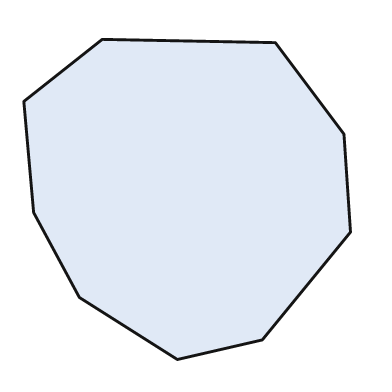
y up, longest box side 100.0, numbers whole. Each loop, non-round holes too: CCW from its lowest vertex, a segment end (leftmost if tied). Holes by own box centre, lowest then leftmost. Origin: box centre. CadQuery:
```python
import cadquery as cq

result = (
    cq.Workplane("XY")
    .moveTo(-3.0, -49.0)
    .lineTo(23.0, -43.0)
    .lineTo(50.0, -10.0)
    .lineTo(48.0, 20.0)
    .lineTo(27.0, 48.0)
    .lineTo(-26.0, 49.0)
    .lineTo(-50.0, 30.0)
    .lineTo(-47.0, -4.0)
    .lineTo(-33.0, -30.0)
    .close()
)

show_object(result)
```